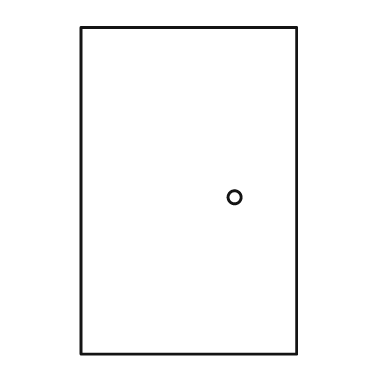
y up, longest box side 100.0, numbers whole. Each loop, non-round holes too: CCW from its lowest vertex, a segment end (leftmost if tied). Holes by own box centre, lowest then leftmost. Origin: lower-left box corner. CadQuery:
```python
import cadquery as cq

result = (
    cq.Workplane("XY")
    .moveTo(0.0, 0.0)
    .lineTo(66.0, 0.0)
    .lineTo(66.0, 100.0)
    .lineTo(0.0, 100.0)
    .close()
    .moveTo(47.0, 48.0)
    .circle(2.0)
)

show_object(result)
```